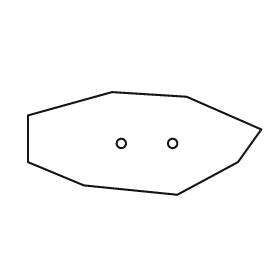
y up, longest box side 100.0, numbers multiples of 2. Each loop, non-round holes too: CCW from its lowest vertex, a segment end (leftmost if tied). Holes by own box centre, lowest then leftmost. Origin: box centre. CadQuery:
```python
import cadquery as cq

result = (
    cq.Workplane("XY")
    .moveTo(14.0, -22.0)
    .lineTo(40.0, -8.0)
    .lineTo(50.0, 6.0)
    .lineTo(18.0, 20.0)
    .lineTo(-14.0, 22.0)
    .lineTo(-50.0, 12.0)
    .lineTo(-50.0, -8.0)
    .lineTo(-26.0, -18.0)
    .close()
    .moveTo(-10.0, 0.0)
    .circle(2.0)
    .moveTo(12.0, 0.0)
    .circle(2.0)
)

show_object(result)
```